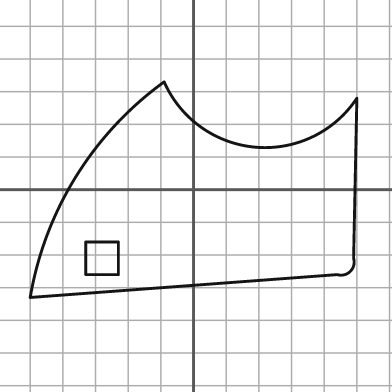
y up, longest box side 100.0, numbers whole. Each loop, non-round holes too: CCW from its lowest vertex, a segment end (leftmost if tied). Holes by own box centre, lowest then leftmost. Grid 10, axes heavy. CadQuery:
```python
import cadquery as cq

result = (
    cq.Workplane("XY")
    .moveTo(-50.0, -33.0)
    .lineTo(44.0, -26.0)
    .threePointArc((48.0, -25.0), (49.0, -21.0))
    .lineTo(50.0, 28.0)
    .threePointArc((19.0, 13.0), (-9.0, 33.0))
    .threePointArc((-36.0, 4.0), (-50.0, -33.0))
    .close()
    .moveTo(-33.0, -26.0)
    .lineTo(-23.0, -26.0)
    .lineTo(-23.0, -16.0)
    .lineTo(-33.0, -16.0)
    .close()
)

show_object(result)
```